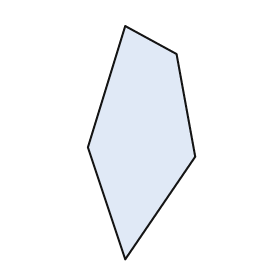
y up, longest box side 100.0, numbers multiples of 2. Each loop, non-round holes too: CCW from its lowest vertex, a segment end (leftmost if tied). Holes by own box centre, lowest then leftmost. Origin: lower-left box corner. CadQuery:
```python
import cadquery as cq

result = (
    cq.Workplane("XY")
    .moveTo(16.0, 0.0)
    .lineTo(46.0, 44.0)
    .lineTo(38.0, 88.0)
    .lineTo(16.0, 100.0)
    .lineTo(0.0, 48.0)
    .close()
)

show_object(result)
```